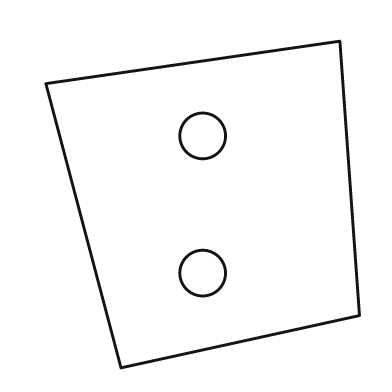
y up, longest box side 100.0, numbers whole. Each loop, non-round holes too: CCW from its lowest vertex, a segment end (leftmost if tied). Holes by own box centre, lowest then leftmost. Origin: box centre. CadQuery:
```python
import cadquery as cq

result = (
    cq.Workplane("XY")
    .moveTo(-25.0, -50.0)
    .lineTo(48.0, -34.0)
    .lineTo(42.0, 50.0)
    .lineTo(-48.0, 37.0)
    .close()
    .moveTo(0.0, -21.0)
    .circle(7.0)
    .moveTo(0.0, 21.0)
    .circle(7.0)
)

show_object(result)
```